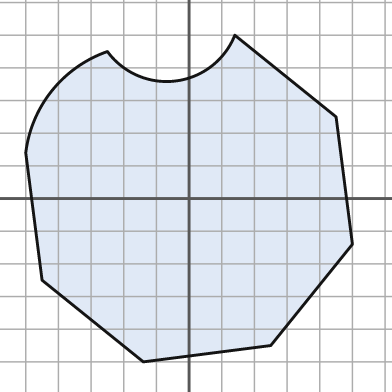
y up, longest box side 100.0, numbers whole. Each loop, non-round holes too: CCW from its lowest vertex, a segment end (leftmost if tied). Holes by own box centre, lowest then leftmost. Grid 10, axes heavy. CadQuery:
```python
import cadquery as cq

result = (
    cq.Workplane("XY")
    .moveTo(-14.0, -50.0)
    .lineTo(25.0, -45.0)
    .lineTo(50.0, -14.0)
    .lineTo(45.0, 25.0)
    .lineTo(14.0, 50.0)
    .threePointArc((-4.0, 36.0), (-25.0, 45.0))
    .threePointArc((-42.0, 33.0), (-50.0, 14.0))
    .lineTo(-45.0, -25.0)
    .close()
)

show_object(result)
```